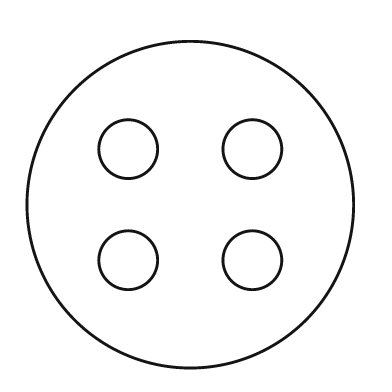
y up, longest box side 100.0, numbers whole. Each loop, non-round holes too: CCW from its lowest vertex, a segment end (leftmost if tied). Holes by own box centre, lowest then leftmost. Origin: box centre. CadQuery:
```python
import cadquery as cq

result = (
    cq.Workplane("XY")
    .moveTo(0.0, 0.0)
    .circle(50.0)
    .moveTo(-19.0, -17.0)
    .circle(9.0)
    .moveTo(19.0, -17.0)
    .circle(9.0)
    .moveTo(-19.0, 17.0)
    .circle(9.0)
    .moveTo(19.0, 17.0)
    .circle(9.0)
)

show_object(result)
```